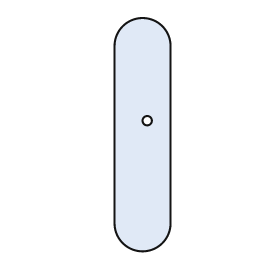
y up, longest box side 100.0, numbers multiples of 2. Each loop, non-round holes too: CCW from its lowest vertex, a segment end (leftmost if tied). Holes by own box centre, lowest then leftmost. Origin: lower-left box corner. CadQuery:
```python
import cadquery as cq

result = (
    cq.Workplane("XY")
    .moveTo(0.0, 12.0)
    .threePointArc((12.0, 0.0), (24.0, 12.0))
    .lineTo(24.0, 88.0)
    .threePointArc((12.0, 100.0), (0.0, 88.0))
    .close()
    .moveTo(14.0, 56.0)
    .circle(2.0)
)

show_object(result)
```